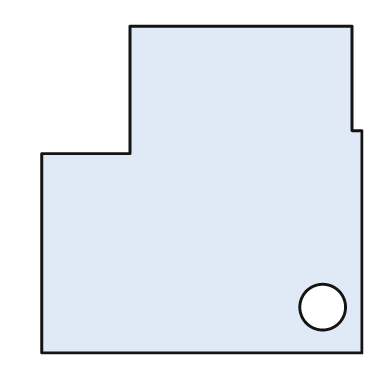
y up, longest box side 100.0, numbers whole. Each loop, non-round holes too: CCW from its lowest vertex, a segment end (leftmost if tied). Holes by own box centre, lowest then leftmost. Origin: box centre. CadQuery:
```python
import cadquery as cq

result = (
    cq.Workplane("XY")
    .moveTo(-49.0, -50.0)
    .lineTo(49.0, -50.0)
    .lineTo(49.0, 18.0)
    .lineTo(46.0, 18.0)
    .lineTo(46.0, 50.0)
    .lineTo(-22.0, 50.0)
    .lineTo(-22.0, 11.0)
    .lineTo(-49.0, 11.0)
    .close()
    .moveTo(37.0, -36.0)
    .circle(7.0)
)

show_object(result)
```